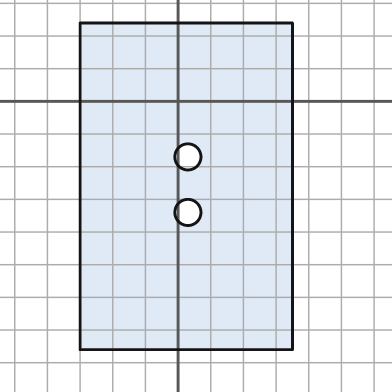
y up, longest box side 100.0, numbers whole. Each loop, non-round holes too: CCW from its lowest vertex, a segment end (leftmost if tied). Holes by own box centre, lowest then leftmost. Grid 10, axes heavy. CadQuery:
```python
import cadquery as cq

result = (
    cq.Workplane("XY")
    .moveTo(-30.0, -76.0)
    .lineTo(35.0, -76.0)
    .lineTo(35.0, 24.0)
    .lineTo(-30.0, 24.0)
    .close()
    .moveTo(3.0, -34.0)
    .circle(4.0)
    .moveTo(3.0, -17.0)
    .circle(4.0)
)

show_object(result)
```